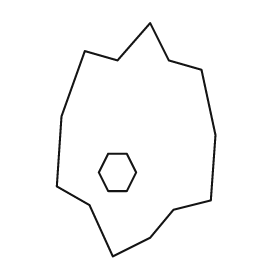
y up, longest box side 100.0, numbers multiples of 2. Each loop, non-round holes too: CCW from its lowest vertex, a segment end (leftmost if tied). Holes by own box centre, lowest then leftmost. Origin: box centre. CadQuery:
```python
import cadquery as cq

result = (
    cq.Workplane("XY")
    .moveTo(-10.0, -50.0)
    .lineTo(6.0, -42.0)
    .lineTo(16.0, -30.0)
    .lineTo(32.0, -26.0)
    .lineTo(34.0, 2.0)
    .lineTo(28.0, 30.0)
    .lineTo(14.0, 34.0)
    .lineTo(6.0, 50.0)
    .lineTo(-8.0, 34.0)
    .lineTo(-22.0, 38.0)
    .lineTo(-32.0, 10.0)
    .lineTo(-34.0, -20.0)
    .lineTo(-20.0, -28.0)
    .close()
    .moveTo(-12.0, -22.0)
    .lineTo(-4.0, -22.0)
    .lineTo(0.0, -14.0)
    .lineTo(-4.0, -6.0)
    .lineTo(-12.0, -6.0)
    .lineTo(-16.0, -14.0)
    .close()
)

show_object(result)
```